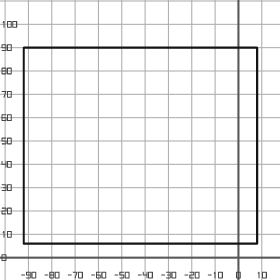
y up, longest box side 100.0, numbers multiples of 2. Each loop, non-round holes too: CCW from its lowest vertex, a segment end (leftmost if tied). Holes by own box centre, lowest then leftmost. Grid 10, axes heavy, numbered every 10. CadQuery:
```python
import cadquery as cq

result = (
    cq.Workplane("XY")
    .moveTo(-92.0, 6.0)
    .lineTo(8.0, 6.0)
    .lineTo(8.0, 90.0)
    .lineTo(-92.0, 90.0)
    .close()
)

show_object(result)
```